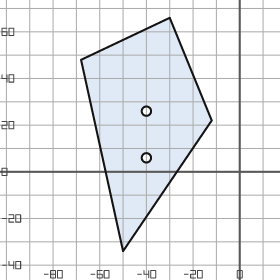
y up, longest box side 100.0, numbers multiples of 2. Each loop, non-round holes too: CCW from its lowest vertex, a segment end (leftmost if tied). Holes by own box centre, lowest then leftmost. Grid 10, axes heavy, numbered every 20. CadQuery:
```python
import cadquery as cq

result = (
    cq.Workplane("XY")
    .moveTo(-50.0, -34.0)
    .lineTo(-12.0, 22.0)
    .lineTo(-30.0, 66.0)
    .lineTo(-68.0, 48.0)
    .close()
    .moveTo(-40.0, 6.0)
    .circle(2.0)
    .moveTo(-40.0, 26.0)
    .circle(2.0)
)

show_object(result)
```